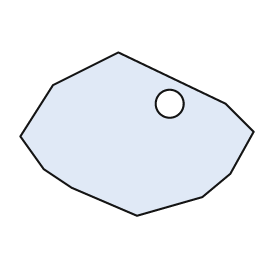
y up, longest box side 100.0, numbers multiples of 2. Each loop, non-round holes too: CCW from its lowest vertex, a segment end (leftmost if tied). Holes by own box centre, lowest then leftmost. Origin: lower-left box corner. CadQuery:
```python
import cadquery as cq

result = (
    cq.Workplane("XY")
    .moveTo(50.0, 0.0)
    .lineTo(78.0, 8.0)
    .lineTo(90.0, 18.0)
    .lineTo(100.0, 36.0)
    .lineTo(88.0, 48.0)
    .lineTo(42.0, 70.0)
    .lineTo(14.0, 56.0)
    .lineTo(0.0, 34.0)
    .lineTo(10.0, 20.0)
    .lineTo(22.0, 12.0)
    .close()
    .moveTo(64.0, 48.0)
    .circle(6.0)
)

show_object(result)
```